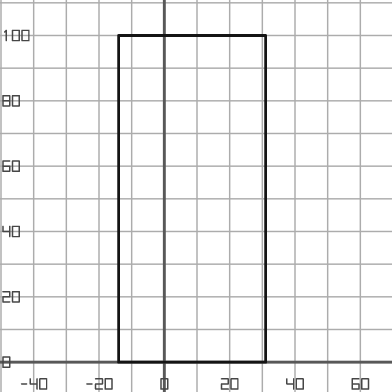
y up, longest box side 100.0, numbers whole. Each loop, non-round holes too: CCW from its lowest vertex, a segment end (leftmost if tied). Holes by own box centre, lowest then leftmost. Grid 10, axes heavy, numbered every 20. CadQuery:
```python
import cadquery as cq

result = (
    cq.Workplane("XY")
    .moveTo(-14.0, 0.0)
    .lineTo(31.0, 0.0)
    .lineTo(31.0, 100.0)
    .lineTo(-14.0, 100.0)
    .close()
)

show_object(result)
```